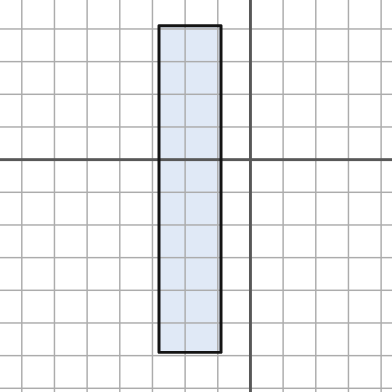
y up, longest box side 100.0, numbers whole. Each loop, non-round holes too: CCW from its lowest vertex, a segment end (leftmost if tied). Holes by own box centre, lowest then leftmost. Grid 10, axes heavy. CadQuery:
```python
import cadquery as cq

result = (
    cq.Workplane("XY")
    .moveTo(-28.0, -59.0)
    .lineTo(-9.0, -59.0)
    .lineTo(-9.0, 41.0)
    .lineTo(-28.0, 41.0)
    .close()
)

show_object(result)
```